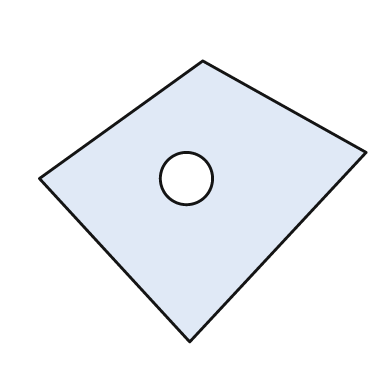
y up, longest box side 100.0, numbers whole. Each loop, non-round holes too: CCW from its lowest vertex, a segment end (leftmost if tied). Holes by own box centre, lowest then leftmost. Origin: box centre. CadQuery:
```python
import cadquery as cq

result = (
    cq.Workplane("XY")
    .moveTo(-4.0, -43.0)
    .lineTo(50.0, 15.0)
    .lineTo(0.0, 43.0)
    .lineTo(-50.0, 7.0)
    .close()
    .moveTo(-5.0, 7.0)
    .circle(8.0)
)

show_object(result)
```